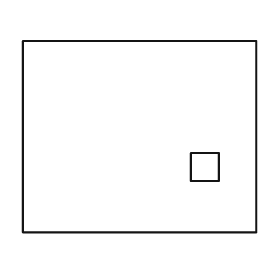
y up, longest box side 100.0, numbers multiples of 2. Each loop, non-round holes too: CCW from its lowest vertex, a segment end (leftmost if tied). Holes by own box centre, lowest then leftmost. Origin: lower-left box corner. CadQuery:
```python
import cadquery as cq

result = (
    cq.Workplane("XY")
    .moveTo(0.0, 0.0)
    .lineTo(100.0, 0.0)
    .lineTo(100.0, 82.0)
    .lineTo(0.0, 82.0)
    .close()
    .moveTo(72.0, 22.0)
    .lineTo(84.0, 22.0)
    .lineTo(84.0, 34.0)
    .lineTo(72.0, 34.0)
    .close()
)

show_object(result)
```